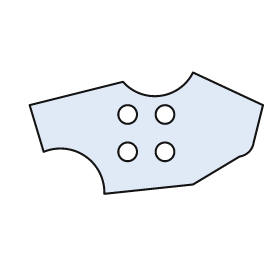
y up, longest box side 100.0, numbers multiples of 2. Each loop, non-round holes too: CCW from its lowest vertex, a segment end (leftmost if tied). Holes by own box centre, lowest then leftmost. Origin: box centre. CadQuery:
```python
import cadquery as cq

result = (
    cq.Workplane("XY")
    .moveTo(-18.0, -26.0)
    .lineTo(20.0, -22.0)
    .lineTo(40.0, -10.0)
    .threePointArc((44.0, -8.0), (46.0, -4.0))
    .lineTo(50.0, 12.0)
    .lineTo(20.0, 26.0)
    .threePointArc((6.0, 16.0), (-10.0, 22.0))
    .lineTo(-50.0, 12.0)
    .lineTo(-44.0, -8.0)
    .threePointArc((-26.0, -10.0), (-18.0, -26.0))
    .close()
    .moveTo(-8.0, -8.0)
    .circle(4.0)
    .moveTo(8.0, -8.0)
    .circle(4.0)
    .moveTo(-8.0, 8.0)
    .circle(4.0)
    .moveTo(8.0, 8.0)
    .circle(4.0)
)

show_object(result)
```